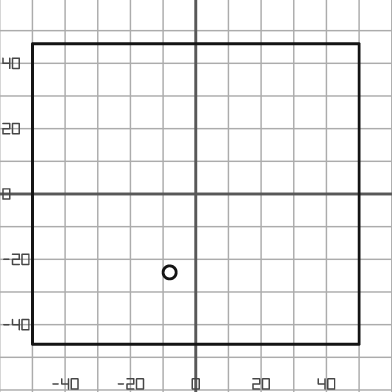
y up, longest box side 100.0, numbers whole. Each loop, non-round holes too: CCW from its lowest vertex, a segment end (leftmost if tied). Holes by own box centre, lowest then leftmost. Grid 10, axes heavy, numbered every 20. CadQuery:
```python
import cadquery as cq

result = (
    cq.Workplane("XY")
    .moveTo(-50.0, -46.0)
    .lineTo(50.0, -46.0)
    .lineTo(50.0, 46.0)
    .lineTo(-50.0, 46.0)
    .close()
    .moveTo(-8.0, -24.0)
    .circle(2.0)
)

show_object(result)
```